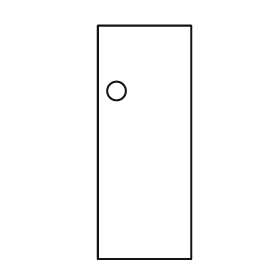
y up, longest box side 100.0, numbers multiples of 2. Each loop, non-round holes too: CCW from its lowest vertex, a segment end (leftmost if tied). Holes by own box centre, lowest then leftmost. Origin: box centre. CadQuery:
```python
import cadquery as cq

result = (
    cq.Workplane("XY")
    .moveTo(-20.0, -50.0)
    .lineTo(20.0, -50.0)
    .lineTo(20.0, 50.0)
    .lineTo(-20.0, 50.0)
    .close()
    .moveTo(-12.0, 22.0)
    .circle(4.0)
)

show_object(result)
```